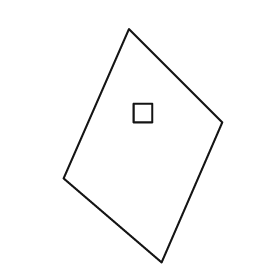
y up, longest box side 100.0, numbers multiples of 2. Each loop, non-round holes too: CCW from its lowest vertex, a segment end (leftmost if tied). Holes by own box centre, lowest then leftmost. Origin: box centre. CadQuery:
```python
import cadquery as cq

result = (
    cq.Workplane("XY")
    .moveTo(8.0, -50.0)
    .lineTo(34.0, 10.0)
    .lineTo(-6.0, 50.0)
    .lineTo(-34.0, -14.0)
    .close()
    .moveTo(-4.0, 10.0)
    .lineTo(4.0, 10.0)
    .lineTo(4.0, 18.0)
    .lineTo(-4.0, 18.0)
    .close()
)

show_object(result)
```